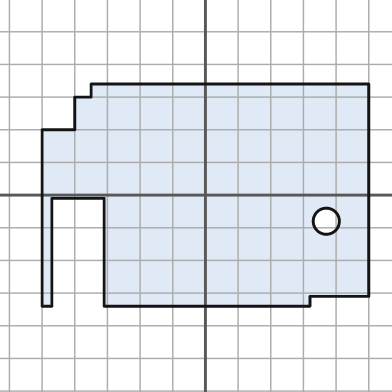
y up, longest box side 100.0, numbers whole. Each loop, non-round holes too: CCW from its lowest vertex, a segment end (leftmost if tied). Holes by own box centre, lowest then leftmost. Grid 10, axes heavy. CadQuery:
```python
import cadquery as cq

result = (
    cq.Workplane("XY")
    .moveTo(-50.0, -34.0)
    .lineTo(-47.0, -34.0)
    .lineTo(-47.0, -1.0)
    .lineTo(-31.0, -1.0)
    .lineTo(-31.0, -34.0)
    .lineTo(32.0, -34.0)
    .lineTo(32.0, -31.0)
    .lineTo(50.0, -31.0)
    .lineTo(50.0, 34.0)
    .lineTo(-35.0, 34.0)
    .lineTo(-35.0, 30.0)
    .lineTo(-40.0, 30.0)
    .lineTo(-40.0, 20.0)
    .lineTo(-50.0, 20.0)
    .close()
    .moveTo(37.0, -8.0)
    .circle(4.0)
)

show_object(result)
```